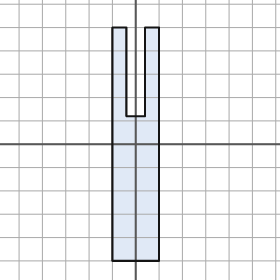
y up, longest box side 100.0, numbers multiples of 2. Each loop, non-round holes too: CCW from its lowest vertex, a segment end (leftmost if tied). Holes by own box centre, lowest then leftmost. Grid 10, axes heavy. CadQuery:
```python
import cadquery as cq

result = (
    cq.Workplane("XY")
    .moveTo(-10.0, -50.0)
    .lineTo(10.0, -50.0)
    .lineTo(10.0, 50.0)
    .lineTo(4.0, 50.0)
    .lineTo(4.0, 12.0)
    .lineTo(-4.0, 12.0)
    .lineTo(-4.0, 50.0)
    .lineTo(-10.0, 50.0)
    .close()
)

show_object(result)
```